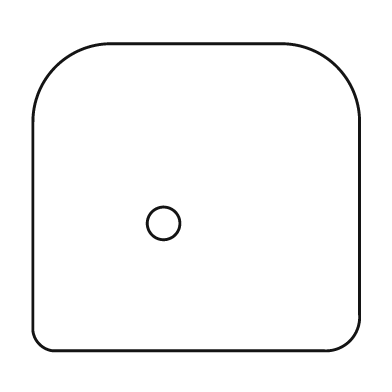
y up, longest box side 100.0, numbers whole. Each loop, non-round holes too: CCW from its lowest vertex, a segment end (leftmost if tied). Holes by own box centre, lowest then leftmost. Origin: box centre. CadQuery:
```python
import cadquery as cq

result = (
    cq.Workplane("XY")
    .moveTo(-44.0, -47.0)
    .lineTo(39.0, -47.0)
    .threePointArc((47.0, -44.0), (50.0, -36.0))
    .lineTo(50.0, 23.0)
    .threePointArc((43.0, 40.0), (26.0, 47.0))
    .lineTo(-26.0, 47.0)
    .threePointArc((-43.0, 40.0), (-50.0, 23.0))
    .lineTo(-50.0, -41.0)
    .threePointArc((-48.0, -45.0), (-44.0, -47.0))
    .close()
    .moveTo(-10.0, -8.0)
    .circle(5.0)
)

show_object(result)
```